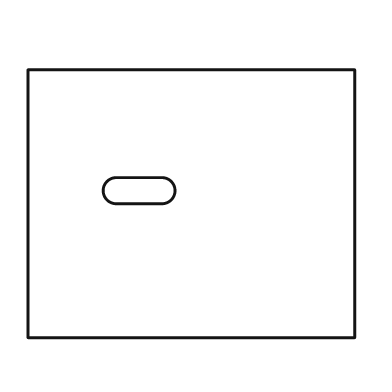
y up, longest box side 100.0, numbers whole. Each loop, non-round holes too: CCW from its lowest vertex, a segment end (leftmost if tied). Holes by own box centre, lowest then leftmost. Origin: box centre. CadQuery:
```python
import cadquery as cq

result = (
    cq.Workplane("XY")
    .moveTo(-50.0, -41.0)
    .lineTo(50.0, -41.0)
    .lineTo(50.0, 41.0)
    .lineTo(-50.0, 41.0)
    .close()
    .moveTo(-23.0, 0.0)
    .lineTo(-9.0, 0.0)
    .threePointArc((-5.0, 4.0), (-9.0, 8.0))
    .lineTo(-23.0, 8.0)
    .threePointArc((-27.0, 4.0), (-23.0, 0.0))
    .close()
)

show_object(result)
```